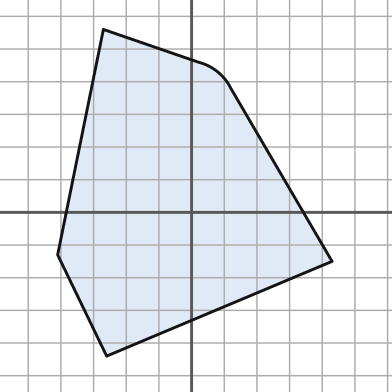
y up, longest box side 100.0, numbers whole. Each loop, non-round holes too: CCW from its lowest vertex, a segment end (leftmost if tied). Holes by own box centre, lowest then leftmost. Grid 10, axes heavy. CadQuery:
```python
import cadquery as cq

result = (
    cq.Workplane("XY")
    .moveTo(-26.0, -44.0)
    .lineTo(43.0, -15.0)
    .lineTo(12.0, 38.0)
    .threePointArc((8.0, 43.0), (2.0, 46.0))
    .lineTo(-27.0, 56.0)
    .lineTo(-41.0, -13.0)
    .close()
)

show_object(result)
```